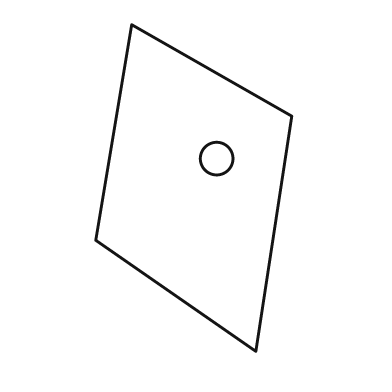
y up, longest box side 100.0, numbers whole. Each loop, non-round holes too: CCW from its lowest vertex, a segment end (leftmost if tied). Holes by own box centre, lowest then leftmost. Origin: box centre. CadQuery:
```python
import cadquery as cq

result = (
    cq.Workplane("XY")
    .moveTo(19.0, -50.0)
    .lineTo(30.0, 22.0)
    .lineTo(-19.0, 50.0)
    .lineTo(-30.0, -16.0)
    .close()
    .moveTo(7.0, 9.0)
    .circle(5.0)
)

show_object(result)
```